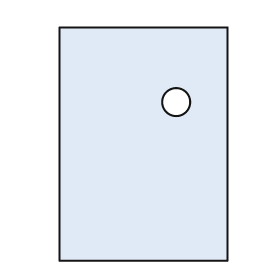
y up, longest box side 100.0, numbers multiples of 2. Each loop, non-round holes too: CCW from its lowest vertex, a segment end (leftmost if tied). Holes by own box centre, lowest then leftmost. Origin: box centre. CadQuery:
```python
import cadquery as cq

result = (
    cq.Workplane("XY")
    .moveTo(-36.0, -50.0)
    .lineTo(36.0, -50.0)
    .lineTo(36.0, 50.0)
    .lineTo(-36.0, 50.0)
    .close()
    .moveTo(14.0, 18.0)
    .circle(6.0)
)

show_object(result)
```